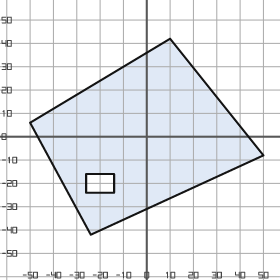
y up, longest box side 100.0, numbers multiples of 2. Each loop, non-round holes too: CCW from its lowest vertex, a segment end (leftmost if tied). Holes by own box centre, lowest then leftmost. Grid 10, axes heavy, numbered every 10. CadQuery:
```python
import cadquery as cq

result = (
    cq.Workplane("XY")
    .moveTo(-24.0, -42.0)
    .lineTo(50.0, -8.0)
    .lineTo(10.0, 42.0)
    .lineTo(-50.0, 6.0)
    .close()
    .moveTo(-26.0, -24.0)
    .lineTo(-14.0, -24.0)
    .lineTo(-14.0, -16.0)
    .lineTo(-26.0, -16.0)
    .close()
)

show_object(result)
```